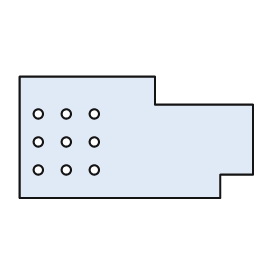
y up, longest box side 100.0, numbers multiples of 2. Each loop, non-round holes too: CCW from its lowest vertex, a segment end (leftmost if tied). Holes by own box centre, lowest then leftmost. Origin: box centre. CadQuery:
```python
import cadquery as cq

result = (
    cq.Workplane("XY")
    .moveTo(-50.0, -26.0)
    .lineTo(36.0, -26.0)
    .lineTo(36.0, -16.0)
    .lineTo(50.0, -16.0)
    .lineTo(50.0, 14.0)
    .lineTo(8.0, 14.0)
    .lineTo(8.0, 26.0)
    .lineTo(-50.0, 26.0)
    .close()
    .moveTo(-42.0, -14.0)
    .circle(2.0)
    .moveTo(-30.0, -14.0)
    .circle(2.0)
    .moveTo(-18.0, -14.0)
    .circle(2.0)
    .moveTo(-42.0, -2.0)
    .circle(2.0)
    .moveTo(-30.0, -2.0)
    .circle(2.0)
    .moveTo(-18.0, -2.0)
    .circle(2.0)
    .moveTo(-42.0, 10.0)
    .circle(2.0)
    .moveTo(-30.0, 10.0)
    .circle(2.0)
    .moveTo(-18.0, 10.0)
    .circle(2.0)
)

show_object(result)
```